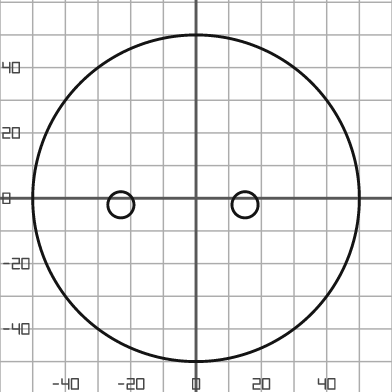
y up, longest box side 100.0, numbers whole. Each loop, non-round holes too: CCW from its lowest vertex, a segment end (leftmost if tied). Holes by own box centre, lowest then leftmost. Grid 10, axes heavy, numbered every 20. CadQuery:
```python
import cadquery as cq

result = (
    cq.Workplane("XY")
    .moveTo(0.0, 0.0)
    .circle(50.0)
    .moveTo(-23.0, -2.0)
    .circle(4.0)
    .moveTo(15.0, -2.0)
    .circle(4.0)
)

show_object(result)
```